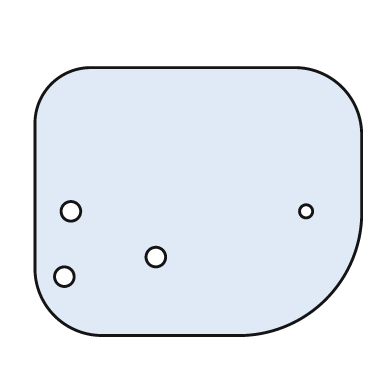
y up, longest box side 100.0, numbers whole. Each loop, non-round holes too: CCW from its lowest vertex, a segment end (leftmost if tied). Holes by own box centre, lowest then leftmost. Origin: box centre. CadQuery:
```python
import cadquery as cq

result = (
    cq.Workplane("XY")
    .moveTo(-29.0, -41.0)
    .lineTo(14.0, -41.0)
    .threePointArc((39.0, -30.0), (50.0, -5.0))
    .lineTo(50.0, 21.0)
    .threePointArc((44.0, 35.0), (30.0, 41.0))
    .lineTo(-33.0, 41.0)
    .threePointArc((-45.0, 36.0), (-50.0, 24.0))
    .lineTo(-50.0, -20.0)
    .threePointArc((-44.0, -35.0), (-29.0, -41.0))
    .close()
    .moveTo(-41.0, -23.0)
    .circle(3.0)
    .moveTo(-13.0, -17.0)
    .circle(3.0)
    .moveTo(-39.0, -3.0)
    .circle(3.0)
    .moveTo(33.0, -3.0)
    .circle(2.0)
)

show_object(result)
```